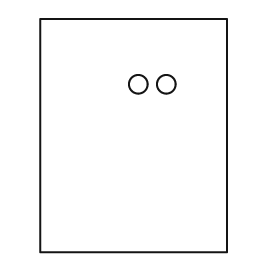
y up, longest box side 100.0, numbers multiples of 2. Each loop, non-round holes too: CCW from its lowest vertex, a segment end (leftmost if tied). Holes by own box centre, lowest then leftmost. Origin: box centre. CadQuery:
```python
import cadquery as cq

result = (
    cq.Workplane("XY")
    .moveTo(-40.0, -50.0)
    .lineTo(40.0, -50.0)
    .lineTo(40.0, 50.0)
    .lineTo(-40.0, 50.0)
    .close()
    .moveTo(2.0, 22.0)
    .circle(4.0)
    .moveTo(14.0, 22.0)
    .circle(4.0)
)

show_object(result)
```